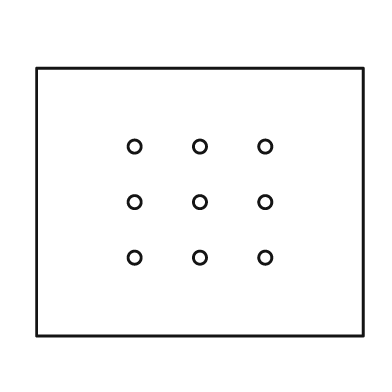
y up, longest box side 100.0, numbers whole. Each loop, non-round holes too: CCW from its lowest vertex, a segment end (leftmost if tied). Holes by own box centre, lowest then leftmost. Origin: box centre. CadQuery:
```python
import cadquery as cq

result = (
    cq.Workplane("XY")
    .moveTo(-50.0, -41.0)
    .lineTo(50.0, -41.0)
    .lineTo(50.0, 41.0)
    .lineTo(-50.0, 41.0)
    .close()
    .moveTo(-20.0, -17.0)
    .circle(2.0)
    .moveTo(0.0, -17.0)
    .circle(2.0)
    .moveTo(20.0, -17.0)
    .circle(2.0)
    .moveTo(-20.0, 0.0)
    .circle(2.0)
    .moveTo(0.0, 0.0)
    .circle(2.0)
    .moveTo(20.0, 0.0)
    .circle(2.0)
    .moveTo(-20.0, 17.0)
    .circle(2.0)
    .moveTo(0.0, 17.0)
    .circle(2.0)
    .moveTo(20.0, 17.0)
    .circle(2.0)
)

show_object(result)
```